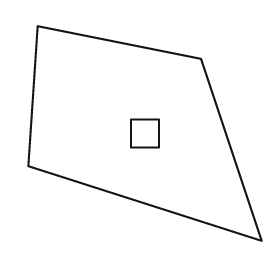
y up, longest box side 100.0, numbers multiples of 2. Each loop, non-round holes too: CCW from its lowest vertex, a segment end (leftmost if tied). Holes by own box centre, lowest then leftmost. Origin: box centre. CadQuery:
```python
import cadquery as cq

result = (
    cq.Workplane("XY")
    .moveTo(50.0, -46.0)
    .lineTo(24.0, 32.0)
    .lineTo(-46.0, 46.0)
    .lineTo(-50.0, -14.0)
    .close()
    .moveTo(-6.0, -6.0)
    .lineTo(6.0, -6.0)
    .lineTo(6.0, 6.0)
    .lineTo(-6.0, 6.0)
    .close()
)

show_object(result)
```